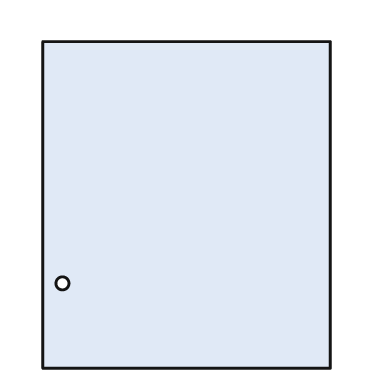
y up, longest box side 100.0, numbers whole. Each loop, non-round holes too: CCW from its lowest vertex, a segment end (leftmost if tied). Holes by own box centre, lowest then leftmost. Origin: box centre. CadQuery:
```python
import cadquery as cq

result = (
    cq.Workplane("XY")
    .moveTo(-44.0, -50.0)
    .lineTo(44.0, -50.0)
    .lineTo(44.0, 50.0)
    .lineTo(-44.0, 50.0)
    .close()
    .moveTo(-38.0, -24.0)
    .circle(2.0)
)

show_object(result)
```